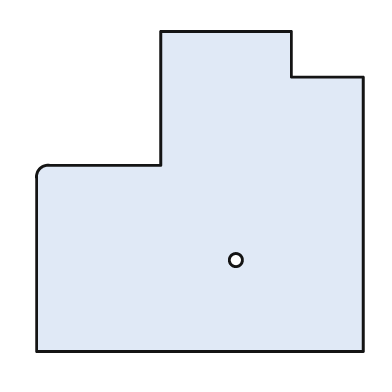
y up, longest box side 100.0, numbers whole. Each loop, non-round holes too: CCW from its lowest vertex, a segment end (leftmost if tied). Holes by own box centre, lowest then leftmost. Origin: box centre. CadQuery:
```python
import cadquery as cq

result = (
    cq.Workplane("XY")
    .moveTo(-50.0, -49.0)
    .lineTo(50.0, -49.0)
    .lineTo(50.0, 35.0)
    .lineTo(28.0, 35.0)
    .lineTo(28.0, 49.0)
    .lineTo(-12.0, 49.0)
    .lineTo(-12.0, 8.0)
    .lineTo(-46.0, 8.0)
    .threePointArc((-49.0, 7.0), (-50.0, 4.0))
    .close()
    .moveTo(11.0, -21.0)
    .circle(2.0)
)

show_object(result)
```